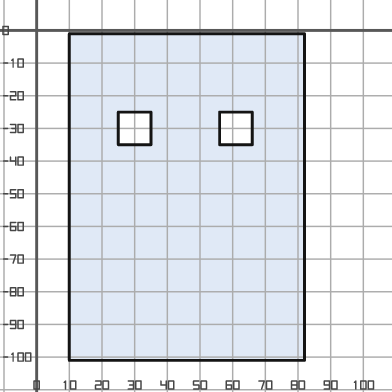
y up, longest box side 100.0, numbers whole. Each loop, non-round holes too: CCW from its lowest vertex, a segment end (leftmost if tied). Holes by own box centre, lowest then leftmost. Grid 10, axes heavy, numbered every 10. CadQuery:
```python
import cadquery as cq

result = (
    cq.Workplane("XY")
    .moveTo(10.0, -101.0)
    .lineTo(82.0, -101.0)
    .lineTo(82.0, -1.0)
    .lineTo(10.0, -1.0)
    .close()
    .moveTo(25.0, -35.0)
    .lineTo(35.0, -35.0)
    .lineTo(35.0, -25.0)
    .lineTo(25.0, -25.0)
    .close()
    .moveTo(56.0, -35.0)
    .lineTo(66.0, -35.0)
    .lineTo(66.0, -25.0)
    .lineTo(56.0, -25.0)
    .close()
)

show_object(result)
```